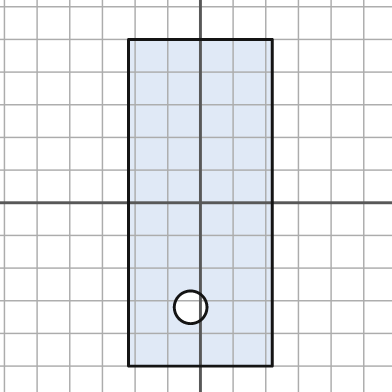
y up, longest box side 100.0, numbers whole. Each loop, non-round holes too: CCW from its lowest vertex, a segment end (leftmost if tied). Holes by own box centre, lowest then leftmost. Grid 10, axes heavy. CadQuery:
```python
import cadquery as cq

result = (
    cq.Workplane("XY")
    .moveTo(-22.0, -50.0)
    .lineTo(22.0, -50.0)
    .lineTo(22.0, 50.0)
    .lineTo(-22.0, 50.0)
    .close()
    .moveTo(-3.0, -32.0)
    .circle(5.0)
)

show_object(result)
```